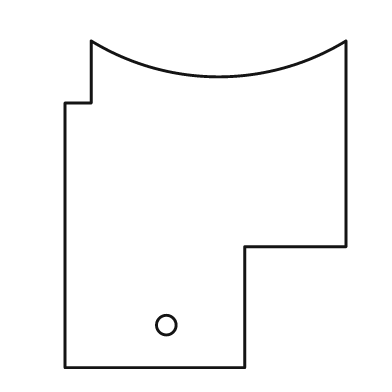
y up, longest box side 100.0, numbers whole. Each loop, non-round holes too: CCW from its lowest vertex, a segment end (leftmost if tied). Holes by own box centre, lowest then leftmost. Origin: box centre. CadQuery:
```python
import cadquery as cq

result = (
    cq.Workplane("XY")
    .moveTo(-43.0, -50.0)
    .lineTo(12.0, -50.0)
    .lineTo(12.0, -13.0)
    .lineTo(43.0, -13.0)
    .lineTo(43.0, 50.0)
    .threePointArc((4.0, 39.0), (-35.0, 50.0))
    .lineTo(-35.0, 31.0)
    .lineTo(-43.0, 31.0)
    .close()
    .moveTo(-12.0, -37.0)
    .circle(3.0)
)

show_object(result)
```